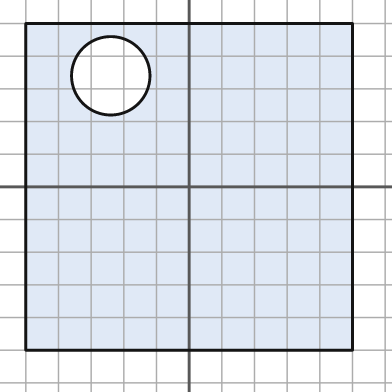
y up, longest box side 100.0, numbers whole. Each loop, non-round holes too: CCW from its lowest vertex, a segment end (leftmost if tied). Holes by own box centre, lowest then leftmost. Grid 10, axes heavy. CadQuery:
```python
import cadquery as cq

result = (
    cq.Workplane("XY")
    .moveTo(-50.0, -50.0)
    .lineTo(50.0, -50.0)
    .lineTo(50.0, 50.0)
    .lineTo(-50.0, 50.0)
    .close()
    .moveTo(-24.0, 34.0)
    .circle(12.0)
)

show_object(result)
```